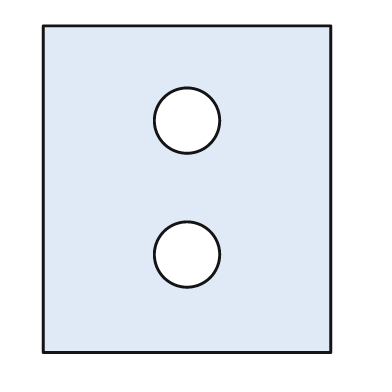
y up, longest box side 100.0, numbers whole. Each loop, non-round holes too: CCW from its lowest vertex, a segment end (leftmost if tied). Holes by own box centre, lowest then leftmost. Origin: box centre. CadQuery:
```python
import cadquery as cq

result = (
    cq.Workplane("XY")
    .moveTo(-44.0, -50.0)
    .lineTo(44.0, -50.0)
    .lineTo(44.0, 50.0)
    .lineTo(-44.0, 50.0)
    .close()
    .moveTo(0.0, -20.0)
    .circle(10.0)
    .moveTo(0.0, 21.0)
    .circle(10.0)
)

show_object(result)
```